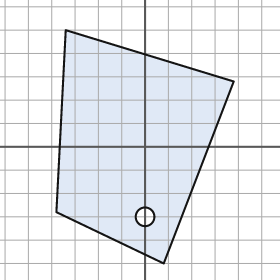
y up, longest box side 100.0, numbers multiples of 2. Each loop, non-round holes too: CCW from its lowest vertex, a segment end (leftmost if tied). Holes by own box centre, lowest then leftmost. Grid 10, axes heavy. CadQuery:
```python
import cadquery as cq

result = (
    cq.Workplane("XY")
    .moveTo(8.0, -50.0)
    .lineTo(38.0, 28.0)
    .lineTo(-34.0, 50.0)
    .lineTo(-38.0, -28.0)
    .close()
    .moveTo(0.0, -30.0)
    .circle(4.0)
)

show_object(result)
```